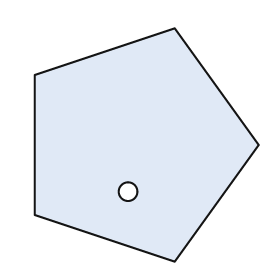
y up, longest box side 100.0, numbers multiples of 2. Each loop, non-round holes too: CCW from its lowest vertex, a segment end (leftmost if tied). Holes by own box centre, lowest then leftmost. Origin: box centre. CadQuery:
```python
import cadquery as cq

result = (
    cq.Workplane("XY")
    .moveTo(12.0, -50.0)
    .lineTo(48.0, 0.0)
    .lineTo(12.0, 50.0)
    .lineTo(-48.0, 30.0)
    .lineTo(-48.0, -30.0)
    .close()
    .moveTo(-8.0, -20.0)
    .circle(4.0)
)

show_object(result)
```